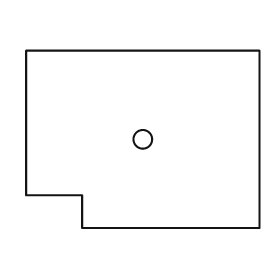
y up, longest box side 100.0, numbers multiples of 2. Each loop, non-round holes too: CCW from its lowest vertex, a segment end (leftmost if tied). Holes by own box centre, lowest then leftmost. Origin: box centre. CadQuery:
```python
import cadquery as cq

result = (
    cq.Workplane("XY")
    .moveTo(-26.0, -38.0)
    .lineTo(50.0, -38.0)
    .lineTo(50.0, 38.0)
    .lineTo(-50.0, 38.0)
    .lineTo(-50.0, -24.0)
    .lineTo(-26.0, -24.0)
    .close()
    .moveTo(0.0, 0.0)
    .circle(4.0)
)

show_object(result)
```